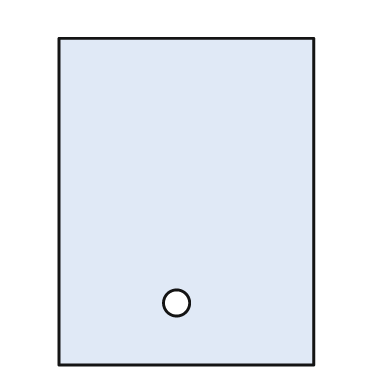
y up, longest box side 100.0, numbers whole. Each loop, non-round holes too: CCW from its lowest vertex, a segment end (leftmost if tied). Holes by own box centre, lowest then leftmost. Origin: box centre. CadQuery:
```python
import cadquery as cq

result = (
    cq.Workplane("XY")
    .moveTo(-39.0, -50.0)
    .lineTo(39.0, -50.0)
    .lineTo(39.0, 50.0)
    .lineTo(-39.0, 50.0)
    .close()
    .moveTo(-3.0, -31.0)
    .circle(4.0)
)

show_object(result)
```